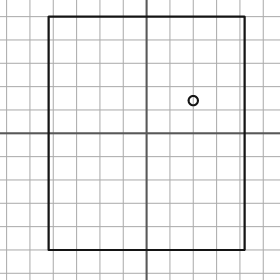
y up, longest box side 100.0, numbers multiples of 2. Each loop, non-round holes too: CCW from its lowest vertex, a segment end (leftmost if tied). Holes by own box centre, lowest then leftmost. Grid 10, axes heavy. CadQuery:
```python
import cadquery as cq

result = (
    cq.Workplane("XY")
    .moveTo(-42.0, -50.0)
    .lineTo(42.0, -50.0)
    .lineTo(42.0, 50.0)
    .lineTo(-42.0, 50.0)
    .close()
    .moveTo(20.0, 14.0)
    .circle(2.0)
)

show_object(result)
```